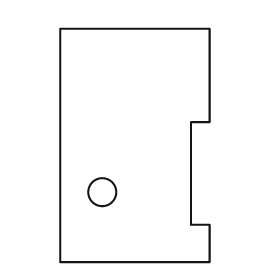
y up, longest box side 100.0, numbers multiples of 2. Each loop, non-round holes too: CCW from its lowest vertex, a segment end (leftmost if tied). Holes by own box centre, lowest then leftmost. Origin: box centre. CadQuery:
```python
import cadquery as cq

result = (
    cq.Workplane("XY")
    .moveTo(-32.0, -50.0)
    .lineTo(32.0, -50.0)
    .lineTo(32.0, -34.0)
    .lineTo(24.0, -34.0)
    .lineTo(24.0, 10.0)
    .lineTo(32.0, 10.0)
    .lineTo(32.0, 50.0)
    .lineTo(-32.0, 50.0)
    .close()
    .moveTo(-14.0, -20.0)
    .circle(6.0)
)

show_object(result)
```